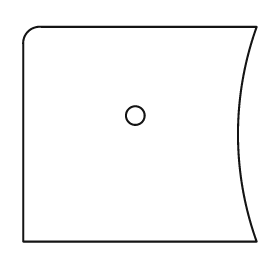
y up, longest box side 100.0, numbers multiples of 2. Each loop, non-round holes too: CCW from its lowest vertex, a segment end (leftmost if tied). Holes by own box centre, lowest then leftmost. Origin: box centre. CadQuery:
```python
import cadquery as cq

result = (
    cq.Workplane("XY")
    .moveTo(-50.0, -46.0)
    .lineTo(50.0, -46.0)
    .threePointArc((42.0, 0.0), (50.0, 46.0))
    .lineTo(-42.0, 46.0)
    .threePointArc((-48.0, 44.0), (-50.0, 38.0))
    .close()
    .moveTo(-2.0, 8.0)
    .circle(4.0)
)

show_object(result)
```